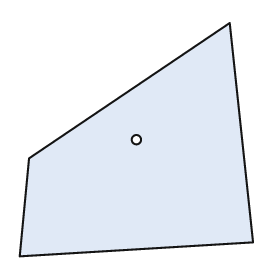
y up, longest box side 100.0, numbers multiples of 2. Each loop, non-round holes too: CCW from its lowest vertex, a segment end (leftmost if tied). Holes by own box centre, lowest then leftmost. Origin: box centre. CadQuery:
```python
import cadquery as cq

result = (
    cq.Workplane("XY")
    .moveTo(-50.0, -50.0)
    .lineTo(50.0, -44.0)
    .lineTo(40.0, 50.0)
    .lineTo(-46.0, -8.0)
    .close()
    .moveTo(0.0, 0.0)
    .circle(2.0)
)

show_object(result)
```